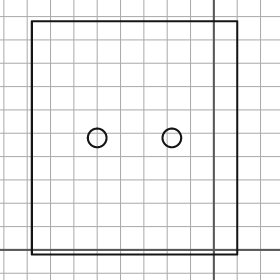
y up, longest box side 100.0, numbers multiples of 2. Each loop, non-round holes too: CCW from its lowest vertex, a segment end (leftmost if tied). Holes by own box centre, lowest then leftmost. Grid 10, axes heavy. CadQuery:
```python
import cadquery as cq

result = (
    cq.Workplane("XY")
    .moveTo(-78.0, -2.0)
    .lineTo(10.0, -2.0)
    .lineTo(10.0, 98.0)
    .lineTo(-78.0, 98.0)
    .close()
    .moveTo(-50.0, 48.0)
    .circle(4.0)
    .moveTo(-18.0, 48.0)
    .circle(4.0)
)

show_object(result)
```